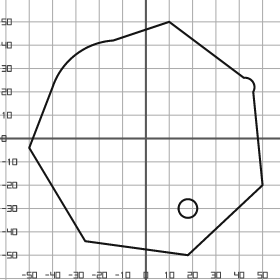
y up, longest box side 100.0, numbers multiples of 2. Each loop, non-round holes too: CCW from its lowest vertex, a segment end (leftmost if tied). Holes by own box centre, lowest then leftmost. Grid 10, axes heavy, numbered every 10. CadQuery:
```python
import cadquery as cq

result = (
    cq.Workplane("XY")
    .moveTo(18.0, -50.0)
    .lineTo(50.0, -20.0)
    .lineTo(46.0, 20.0)
    .threePointArc((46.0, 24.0), (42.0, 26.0))
    .lineTo(10.0, 50.0)
    .lineTo(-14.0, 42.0)
    .threePointArc((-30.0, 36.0), (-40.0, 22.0))
    .lineTo(-50.0, -4.0)
    .lineTo(-26.0, -44.0)
    .close()
    .moveTo(18.0, -30.0)
    .circle(4.0)
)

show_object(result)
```